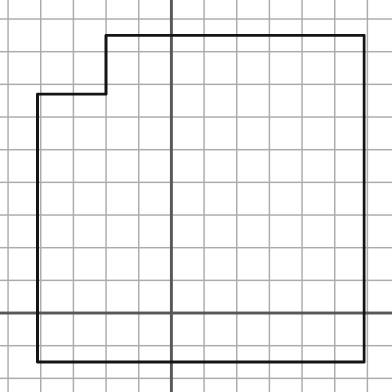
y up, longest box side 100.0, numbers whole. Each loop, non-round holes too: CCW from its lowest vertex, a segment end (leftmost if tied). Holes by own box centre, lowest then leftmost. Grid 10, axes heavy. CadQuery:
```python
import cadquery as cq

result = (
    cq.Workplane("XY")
    .moveTo(-41.0, -15.0)
    .lineTo(59.0, -15.0)
    .lineTo(59.0, 85.0)
    .lineTo(-20.0, 85.0)
    .lineTo(-20.0, 67.0)
    .lineTo(-41.0, 67.0)
    .close()
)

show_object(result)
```